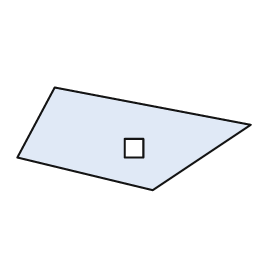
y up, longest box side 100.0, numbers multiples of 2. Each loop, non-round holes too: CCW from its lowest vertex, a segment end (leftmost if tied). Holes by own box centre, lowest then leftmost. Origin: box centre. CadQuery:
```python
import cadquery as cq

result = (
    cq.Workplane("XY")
    .moveTo(8.0, -22.0)
    .lineTo(50.0, 6.0)
    .lineTo(-34.0, 22.0)
    .lineTo(-50.0, -8.0)
    .close()
    .moveTo(-4.0, -8.0)
    .lineTo(4.0, -8.0)
    .lineTo(4.0, 0.0)
    .lineTo(-4.0, 0.0)
    .close()
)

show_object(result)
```